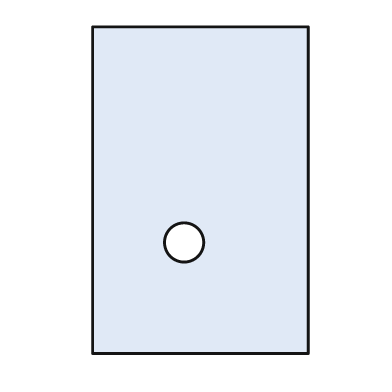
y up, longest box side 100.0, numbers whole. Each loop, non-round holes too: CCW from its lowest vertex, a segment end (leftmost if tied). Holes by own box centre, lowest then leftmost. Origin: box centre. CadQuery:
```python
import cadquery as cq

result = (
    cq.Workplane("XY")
    .moveTo(-33.0, -50.0)
    .lineTo(33.0, -50.0)
    .lineTo(33.0, 50.0)
    .lineTo(-33.0, 50.0)
    .close()
    .moveTo(-5.0, -16.0)
    .circle(6.0)
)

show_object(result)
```